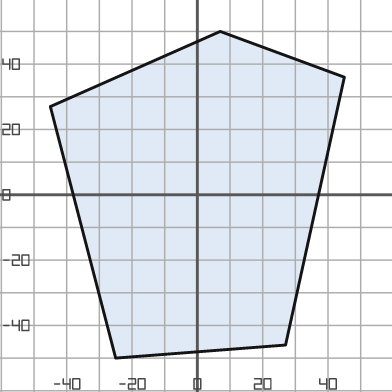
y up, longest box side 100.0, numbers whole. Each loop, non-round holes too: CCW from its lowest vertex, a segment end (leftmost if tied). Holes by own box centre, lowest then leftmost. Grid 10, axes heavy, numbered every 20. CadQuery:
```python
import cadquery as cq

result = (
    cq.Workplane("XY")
    .moveTo(-25.0, -50.0)
    .lineTo(27.0, -46.0)
    .lineTo(45.0, 36.0)
    .lineTo(7.0, 50.0)
    .lineTo(-45.0, 27.0)
    .close()
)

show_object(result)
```